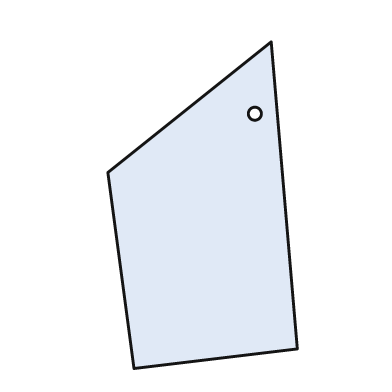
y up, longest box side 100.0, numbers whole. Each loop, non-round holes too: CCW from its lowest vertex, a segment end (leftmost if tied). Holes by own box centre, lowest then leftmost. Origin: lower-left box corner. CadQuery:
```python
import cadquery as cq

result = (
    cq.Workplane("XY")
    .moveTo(8.0, 0.0)
    .lineTo(58.0, 6.0)
    .lineTo(50.0, 100.0)
    .lineTo(0.0, 60.0)
    .close()
    .moveTo(45.0, 78.0)
    .circle(2.0)
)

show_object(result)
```